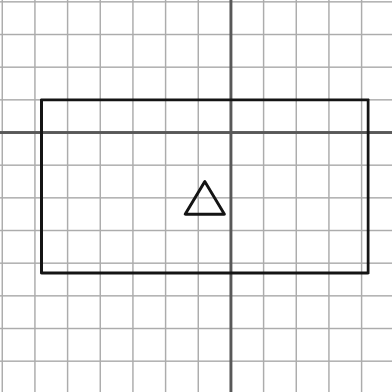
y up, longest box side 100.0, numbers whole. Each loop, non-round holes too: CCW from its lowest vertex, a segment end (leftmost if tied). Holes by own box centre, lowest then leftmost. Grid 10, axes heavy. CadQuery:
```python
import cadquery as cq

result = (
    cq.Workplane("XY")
    .moveTo(-58.0, -43.0)
    .lineTo(42.0, -43.0)
    .lineTo(42.0, 10.0)
    .lineTo(-58.0, 10.0)
    .close()
    .moveTo(-14.0, -25.0)
    .lineTo(-2.0, -25.0)
    .lineTo(-8.0, -15.0)
    .close()
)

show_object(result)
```